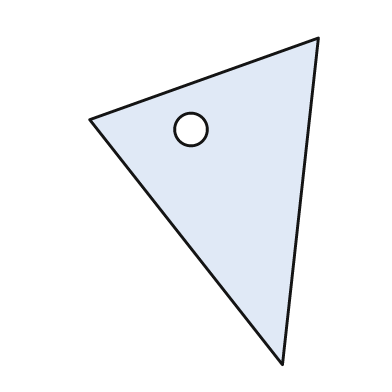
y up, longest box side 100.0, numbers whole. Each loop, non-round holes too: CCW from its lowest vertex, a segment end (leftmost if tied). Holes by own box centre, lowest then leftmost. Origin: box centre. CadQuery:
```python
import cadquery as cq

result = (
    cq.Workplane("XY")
    .moveTo(24.0, -50.0)
    .lineTo(35.0, 50.0)
    .lineTo(-35.0, 25.0)
    .close()
    .moveTo(-4.0, 22.0)
    .circle(5.0)
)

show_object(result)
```